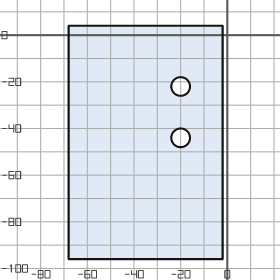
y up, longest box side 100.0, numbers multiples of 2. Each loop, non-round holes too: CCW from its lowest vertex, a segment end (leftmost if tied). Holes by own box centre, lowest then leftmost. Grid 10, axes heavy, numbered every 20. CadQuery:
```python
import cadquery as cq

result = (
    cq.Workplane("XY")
    .moveTo(-68.0, -96.0)
    .lineTo(-2.0, -96.0)
    .lineTo(-2.0, 4.0)
    .lineTo(-68.0, 4.0)
    .close()
    .moveTo(-20.0, -44.0)
    .circle(4.0)
    .moveTo(-20.0, -22.0)
    .circle(4.0)
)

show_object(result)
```